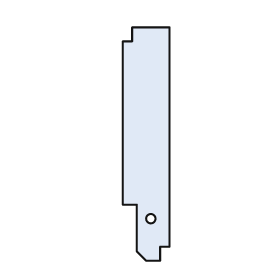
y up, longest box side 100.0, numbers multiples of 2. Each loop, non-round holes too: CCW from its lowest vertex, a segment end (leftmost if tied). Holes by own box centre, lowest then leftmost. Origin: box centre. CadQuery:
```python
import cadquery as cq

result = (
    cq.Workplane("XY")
    .moveTo(0.0, -50.0)
    .lineTo(6.0, -50.0)
    .lineTo(6.0, -44.0)
    .lineTo(10.0, -44.0)
    .lineTo(10.0, 50.0)
    .lineTo(-6.0, 50.0)
    .lineTo(-6.0, 44.0)
    .lineTo(-10.0, 44.0)
    .lineTo(-10.0, -26.0)
    .lineTo(-4.0, -26.0)
    .lineTo(-4.0, -46.0)
    .close()
    .moveTo(2.0, -32.0)
    .circle(2.0)
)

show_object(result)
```